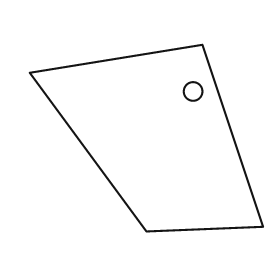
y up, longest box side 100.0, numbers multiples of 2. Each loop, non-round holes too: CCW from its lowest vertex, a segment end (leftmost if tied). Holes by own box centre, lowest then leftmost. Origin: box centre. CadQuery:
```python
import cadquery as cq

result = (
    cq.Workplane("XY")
    .moveTo(0.0, -40.0)
    .lineTo(50.0, -38.0)
    .lineTo(24.0, 40.0)
    .lineTo(-50.0, 28.0)
    .close()
    .moveTo(20.0, 20.0)
    .circle(4.0)
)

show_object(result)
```